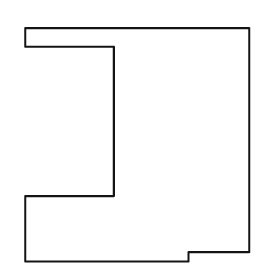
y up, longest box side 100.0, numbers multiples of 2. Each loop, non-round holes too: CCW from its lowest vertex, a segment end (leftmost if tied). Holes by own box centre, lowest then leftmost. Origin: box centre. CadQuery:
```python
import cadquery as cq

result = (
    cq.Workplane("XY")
    .moveTo(-48.0, -50.0)
    .lineTo(22.0, -50.0)
    .lineTo(22.0, -46.0)
    .lineTo(48.0, -46.0)
    .lineTo(48.0, 50.0)
    .lineTo(-48.0, 50.0)
    .lineTo(-48.0, 42.0)
    .lineTo(-10.0, 42.0)
    .lineTo(-10.0, -22.0)
    .lineTo(-48.0, -22.0)
    .close()
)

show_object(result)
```